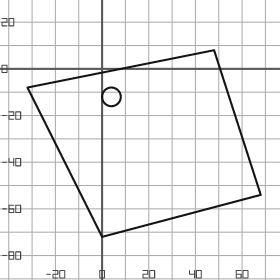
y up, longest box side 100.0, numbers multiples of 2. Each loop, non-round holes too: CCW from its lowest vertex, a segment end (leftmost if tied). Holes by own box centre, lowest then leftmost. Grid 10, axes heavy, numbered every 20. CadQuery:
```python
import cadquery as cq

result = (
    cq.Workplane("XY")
    .moveTo(0.0, -72.0)
    .lineTo(68.0, -54.0)
    .lineTo(48.0, 8.0)
    .lineTo(-32.0, -8.0)
    .close()
    .moveTo(4.0, -12.0)
    .circle(4.0)
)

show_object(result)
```